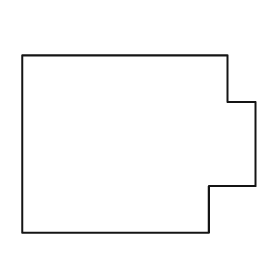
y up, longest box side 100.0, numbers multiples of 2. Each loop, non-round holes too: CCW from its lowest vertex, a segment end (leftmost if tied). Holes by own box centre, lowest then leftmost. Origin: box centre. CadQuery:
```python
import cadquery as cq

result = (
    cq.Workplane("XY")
    .moveTo(-50.0, -38.0)
    .lineTo(30.0, -38.0)
    .lineTo(30.0, -18.0)
    .lineTo(50.0, -18.0)
    .lineTo(50.0, 18.0)
    .lineTo(38.0, 18.0)
    .lineTo(38.0, 38.0)
    .lineTo(-50.0, 38.0)
    .close()
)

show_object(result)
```